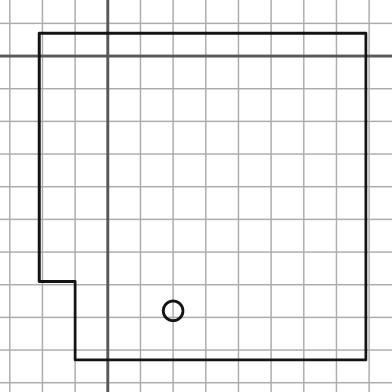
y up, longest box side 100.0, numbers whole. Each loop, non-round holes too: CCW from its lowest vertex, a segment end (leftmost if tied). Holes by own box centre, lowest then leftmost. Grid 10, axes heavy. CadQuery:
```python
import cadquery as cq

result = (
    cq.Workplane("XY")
    .moveTo(-10.0, -93.0)
    .lineTo(79.0, -93.0)
    .lineTo(79.0, 7.0)
    .lineTo(-21.0, 7.0)
    .lineTo(-21.0, -69.0)
    .lineTo(-10.0, -69.0)
    .close()
    .moveTo(20.0, -78.0)
    .circle(3.0)
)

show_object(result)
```